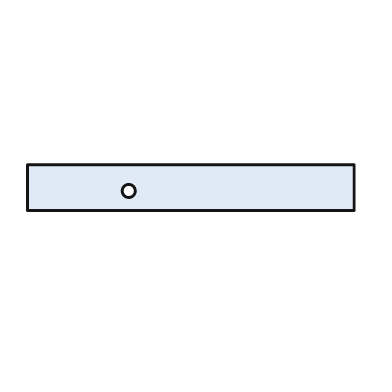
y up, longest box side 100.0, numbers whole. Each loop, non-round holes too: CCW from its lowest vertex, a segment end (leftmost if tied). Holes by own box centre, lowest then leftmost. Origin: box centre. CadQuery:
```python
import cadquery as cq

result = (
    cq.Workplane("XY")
    .moveTo(-50.0, -7.0)
    .lineTo(50.0, -7.0)
    .lineTo(50.0, 7.0)
    .lineTo(-50.0, 7.0)
    .close()
    .moveTo(-19.0, -1.0)
    .circle(2.0)
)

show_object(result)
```